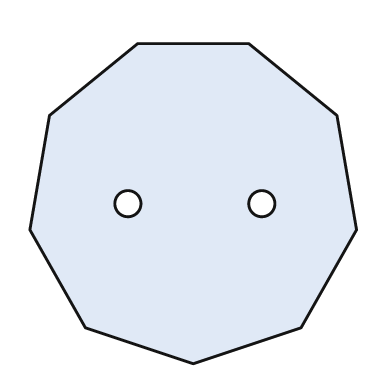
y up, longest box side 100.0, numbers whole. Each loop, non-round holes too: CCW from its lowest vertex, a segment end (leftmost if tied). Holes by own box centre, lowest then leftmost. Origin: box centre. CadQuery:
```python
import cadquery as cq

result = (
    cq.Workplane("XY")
    .moveTo(0.0, -49.0)
    .lineTo(33.0, -38.0)
    .lineTo(50.0, -8.0)
    .lineTo(44.0, 27.0)
    .lineTo(17.0, 49.0)
    .lineTo(-17.0, 49.0)
    .lineTo(-44.0, 27.0)
    .lineTo(-50.0, -8.0)
    .lineTo(-33.0, -38.0)
    .close()
    .moveTo(-20.0, 0.0)
    .circle(4.0)
    .moveTo(21.0, 0.0)
    .circle(4.0)
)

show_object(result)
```